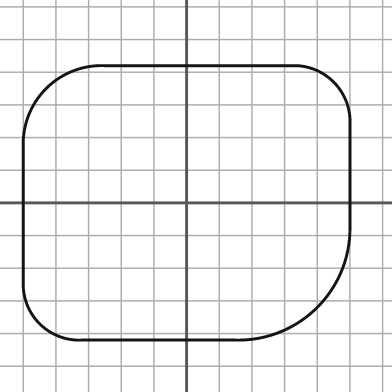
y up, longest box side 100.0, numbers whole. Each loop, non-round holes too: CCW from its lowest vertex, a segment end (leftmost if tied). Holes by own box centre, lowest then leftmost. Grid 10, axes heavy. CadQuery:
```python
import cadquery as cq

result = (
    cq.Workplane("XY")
    .moveTo(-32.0, -42.0)
    .lineTo(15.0, -42.0)
    .threePointArc((40.0, -32.0), (50.0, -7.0))
    .lineTo(50.0, 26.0)
    .threePointArc((45.0, 37.0), (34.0, 42.0))
    .lineTo(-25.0, 42.0)
    .threePointArc((-43.0, 35.0), (-50.0, 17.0))
    .lineTo(-50.0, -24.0)
    .threePointArc((-45.0, -37.0), (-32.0, -42.0))
    .close()
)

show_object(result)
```